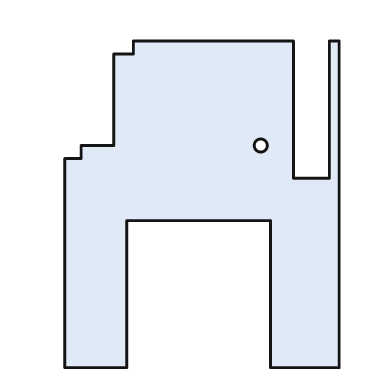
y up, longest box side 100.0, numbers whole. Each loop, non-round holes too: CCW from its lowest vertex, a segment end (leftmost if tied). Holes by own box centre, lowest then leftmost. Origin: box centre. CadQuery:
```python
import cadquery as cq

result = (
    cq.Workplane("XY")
    .moveTo(-42.0, -50.0)
    .lineTo(-23.0, -50.0)
    .lineTo(-23.0, -5.0)
    .lineTo(21.0, -5.0)
    .lineTo(21.0, -50.0)
    .lineTo(42.0, -50.0)
    .lineTo(42.0, 50.0)
    .lineTo(39.0, 50.0)
    .lineTo(39.0, 8.0)
    .lineTo(28.0, 8.0)
    .lineTo(28.0, 50.0)
    .lineTo(-21.0, 50.0)
    .lineTo(-21.0, 46.0)
    .lineTo(-27.0, 46.0)
    .lineTo(-27.0, 18.0)
    .lineTo(-37.0, 18.0)
    .lineTo(-37.0, 14.0)
    .lineTo(-42.0, 14.0)
    .close()
    .moveTo(18.0, 18.0)
    .circle(2.0)
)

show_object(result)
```